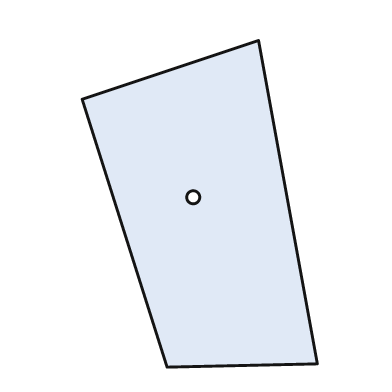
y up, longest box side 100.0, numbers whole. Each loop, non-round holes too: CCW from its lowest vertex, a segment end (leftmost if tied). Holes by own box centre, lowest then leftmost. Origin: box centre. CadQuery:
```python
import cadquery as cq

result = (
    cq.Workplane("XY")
    .moveTo(-10.0, -50.0)
    .lineTo(36.0, -49.0)
    .lineTo(18.0, 50.0)
    .lineTo(-36.0, 32.0)
    .close()
    .moveTo(-2.0, 2.0)
    .circle(2.0)
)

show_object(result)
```